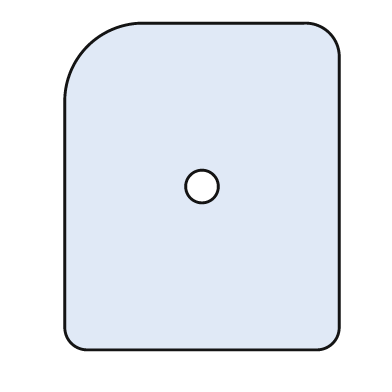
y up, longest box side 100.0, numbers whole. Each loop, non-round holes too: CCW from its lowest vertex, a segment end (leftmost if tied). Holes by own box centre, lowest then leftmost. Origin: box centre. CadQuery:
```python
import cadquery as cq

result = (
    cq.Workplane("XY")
    .moveTo(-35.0, -50.0)
    .lineTo(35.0, -50.0)
    .threePointArc((40.0, -48.0), (42.0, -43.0))
    .lineTo(42.0, 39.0)
    .threePointArc((39.0, 47.0), (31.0, 50.0))
    .lineTo(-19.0, 50.0)
    .threePointArc((-35.0, 43.0), (-42.0, 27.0))
    .lineTo(-42.0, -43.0)
    .threePointArc((-40.0, -48.0), (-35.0, -50.0))
    .close()
    .moveTo(0.0, 0.0)
    .circle(5.0)
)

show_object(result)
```